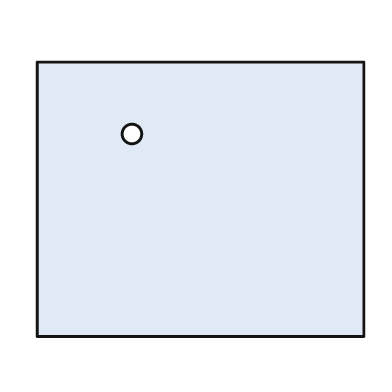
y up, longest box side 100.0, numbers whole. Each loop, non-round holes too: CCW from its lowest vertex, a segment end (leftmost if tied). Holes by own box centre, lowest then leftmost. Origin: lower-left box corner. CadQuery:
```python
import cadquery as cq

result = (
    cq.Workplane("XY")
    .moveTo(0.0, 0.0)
    .lineTo(100.0, 0.0)
    .lineTo(100.0, 84.0)
    .lineTo(0.0, 84.0)
    .close()
    .moveTo(29.0, 62.0)
    .circle(3.0)
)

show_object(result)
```